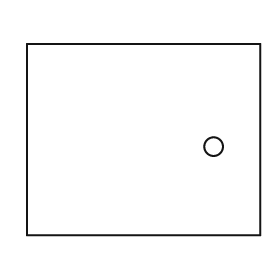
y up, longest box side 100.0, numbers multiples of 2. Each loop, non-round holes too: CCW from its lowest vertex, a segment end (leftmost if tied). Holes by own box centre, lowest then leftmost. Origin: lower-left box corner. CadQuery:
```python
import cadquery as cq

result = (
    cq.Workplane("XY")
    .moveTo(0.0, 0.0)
    .lineTo(100.0, 0.0)
    .lineTo(100.0, 82.0)
    .lineTo(0.0, 82.0)
    .close()
    .moveTo(80.0, 38.0)
    .circle(4.0)
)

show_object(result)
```